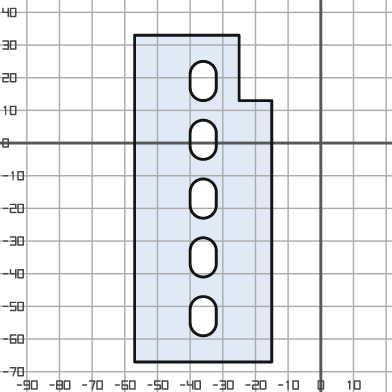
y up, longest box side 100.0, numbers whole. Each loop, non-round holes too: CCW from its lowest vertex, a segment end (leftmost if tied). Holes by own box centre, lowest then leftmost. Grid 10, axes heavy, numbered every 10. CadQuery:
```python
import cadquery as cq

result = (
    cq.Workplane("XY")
    .moveTo(-57.0, -67.0)
    .lineTo(-15.0, -67.0)
    .lineTo(-15.0, 13.0)
    .lineTo(-25.0, 13.0)
    .lineTo(-25.0, 33.0)
    .lineTo(-57.0, 33.0)
    .close()
    .moveTo(-40.0, -55.0)
    .threePointArc((-36.0, -59.0), (-32.0, -55.0))
    .lineTo(-32.0, -51.0)
    .threePointArc((-36.0, -47.0), (-40.0, -51.0))
    .close()
    .moveTo(-40.0, -37.0)
    .threePointArc((-36.0, -41.0), (-32.0, -37.0))
    .lineTo(-32.0, -33.0)
    .threePointArc((-36.0, -29.0), (-40.0, -33.0))
    .close()
    .moveTo(-40.0, -19.0)
    .threePointArc((-36.0, -23.0), (-32.0, -19.0))
    .lineTo(-32.0, -15.0)
    .threePointArc((-36.0, -11.0), (-40.0, -15.0))
    .close()
    .moveTo(-40.0, -1.0)
    .threePointArc((-36.0, -5.0), (-32.0, -1.0))
    .lineTo(-32.0, 3.0)
    .threePointArc((-36.0, 7.0), (-40.0, 3.0))
    .close()
    .moveTo(-40.0, 17.0)
    .threePointArc((-36.0, 13.0), (-32.0, 17.0))
    .lineTo(-32.0, 21.0)
    .threePointArc((-36.0, 25.0), (-40.0, 21.0))
    .close()
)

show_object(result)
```